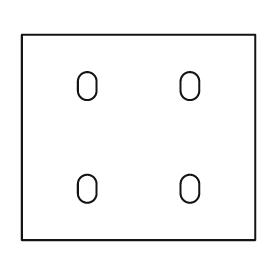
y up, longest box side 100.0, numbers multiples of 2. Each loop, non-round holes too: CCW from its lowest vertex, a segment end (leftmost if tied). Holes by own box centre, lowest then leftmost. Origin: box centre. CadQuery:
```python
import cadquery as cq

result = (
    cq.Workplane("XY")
    .moveTo(-50.0, -44.0)
    .lineTo(50.0, -44.0)
    .lineTo(50.0, 44.0)
    .lineTo(-50.0, 44.0)
    .close()
    .moveTo(-26.0, -24.0)
    .threePointArc((-22.0, -28.0), (-18.0, -24.0))
    .lineTo(-18.0, -20.0)
    .threePointArc((-22.0, -16.0), (-26.0, -20.0))
    .close()
    .moveTo(18.0, -24.0)
    .threePointArc((22.0, -28.0), (26.0, -24.0))
    .lineTo(26.0, -20.0)
    .threePointArc((22.0, -16.0), (18.0, -20.0))
    .close()
    .moveTo(-26.0, 20.0)
    .threePointArc((-22.0, 16.0), (-18.0, 20.0))
    .lineTo(-18.0, 24.0)
    .threePointArc((-22.0, 28.0), (-26.0, 24.0))
    .close()
    .moveTo(18.0, 20.0)
    .threePointArc((22.0, 16.0), (26.0, 20.0))
    .lineTo(26.0, 24.0)
    .threePointArc((22.0, 28.0), (18.0, 24.0))
    .close()
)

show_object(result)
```